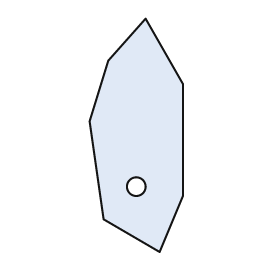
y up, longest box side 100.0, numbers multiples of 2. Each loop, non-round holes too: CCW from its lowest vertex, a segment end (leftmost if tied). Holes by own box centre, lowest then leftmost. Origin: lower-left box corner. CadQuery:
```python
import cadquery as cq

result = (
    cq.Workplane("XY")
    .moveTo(30.0, 0.0)
    .lineTo(40.0, 24.0)
    .lineTo(40.0, 72.0)
    .lineTo(24.0, 100.0)
    .lineTo(8.0, 82.0)
    .lineTo(0.0, 56.0)
    .lineTo(6.0, 14.0)
    .close()
    .moveTo(20.0, 28.0)
    .circle(4.0)
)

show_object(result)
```